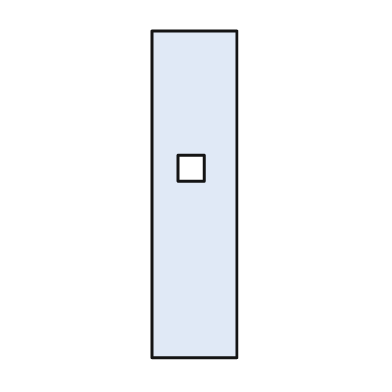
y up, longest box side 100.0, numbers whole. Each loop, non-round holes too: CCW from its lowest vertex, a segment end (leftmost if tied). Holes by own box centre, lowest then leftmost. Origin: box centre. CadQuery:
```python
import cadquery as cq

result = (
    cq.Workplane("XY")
    .moveTo(-13.0, -50.0)
    .lineTo(13.0, -50.0)
    .lineTo(13.0, 50.0)
    .lineTo(-13.0, 50.0)
    .close()
    .moveTo(-5.0, 4.0)
    .lineTo(3.0, 4.0)
    .lineTo(3.0, 12.0)
    .lineTo(-5.0, 12.0)
    .close()
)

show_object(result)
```